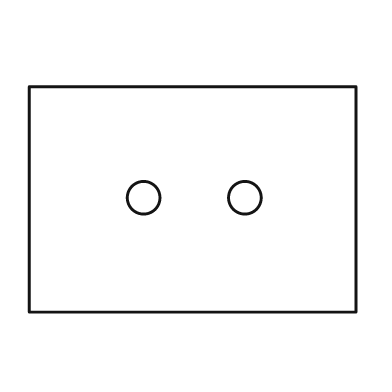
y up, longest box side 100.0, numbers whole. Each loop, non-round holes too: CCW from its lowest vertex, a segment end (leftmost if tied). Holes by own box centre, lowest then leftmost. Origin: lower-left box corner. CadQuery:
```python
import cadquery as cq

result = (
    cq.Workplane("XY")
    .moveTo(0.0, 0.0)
    .lineTo(100.0, 0.0)
    .lineTo(100.0, 69.0)
    .lineTo(0.0, 69.0)
    .close()
    .moveTo(35.0, 35.0)
    .circle(5.0)
    .moveTo(66.0, 35.0)
    .circle(5.0)
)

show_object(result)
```